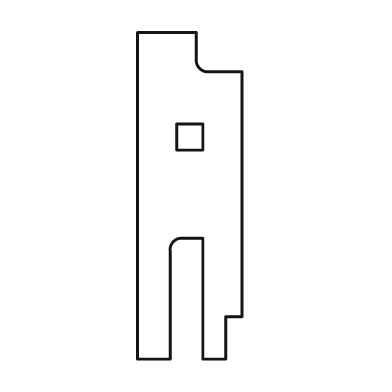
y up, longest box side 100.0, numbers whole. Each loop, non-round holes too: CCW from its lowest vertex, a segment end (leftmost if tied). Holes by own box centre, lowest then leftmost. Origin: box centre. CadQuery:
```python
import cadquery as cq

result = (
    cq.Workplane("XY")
    .moveTo(-16.0, -50.0)
    .lineTo(-6.0, -50.0)
    .lineTo(-6.0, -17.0)
    .threePointArc((-5.0, -14.0), (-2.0, -13.0))
    .lineTo(4.0, -13.0)
    .lineTo(4.0, -50.0)
    .lineTo(11.0, -50.0)
    .lineTo(11.0, -37.0)
    .lineTo(16.0, -37.0)
    .lineTo(16.0, 38.0)
    .lineTo(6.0, 38.0)
    .threePointArc((3.0, 39.0), (2.0, 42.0))
    .lineTo(2.0, 50.0)
    .lineTo(-16.0, 50.0)
    .close()
    .moveTo(-4.0, 14.0)
    .lineTo(4.0, 14.0)
    .lineTo(4.0, 22.0)
    .lineTo(-4.0, 22.0)
    .close()
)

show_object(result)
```